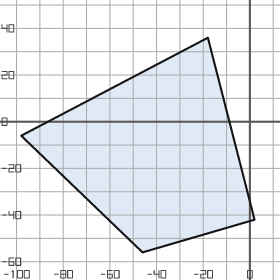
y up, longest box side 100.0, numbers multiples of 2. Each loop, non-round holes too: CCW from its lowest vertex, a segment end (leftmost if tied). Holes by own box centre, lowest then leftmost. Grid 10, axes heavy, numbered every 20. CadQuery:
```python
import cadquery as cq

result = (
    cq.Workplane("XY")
    .moveTo(-46.0, -56.0)
    .lineTo(2.0, -42.0)
    .lineTo(-18.0, 36.0)
    .lineTo(-98.0, -6.0)
    .close()
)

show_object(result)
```